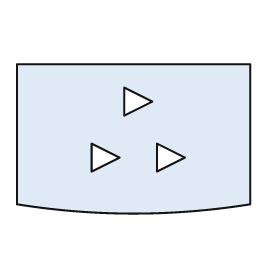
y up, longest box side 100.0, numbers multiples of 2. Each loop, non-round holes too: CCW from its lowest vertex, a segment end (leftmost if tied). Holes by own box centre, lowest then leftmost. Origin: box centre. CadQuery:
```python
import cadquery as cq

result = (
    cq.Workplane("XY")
    .moveTo(-50.0, -28.0)
    .threePointArc((0.0, -32.0), (50.0, -28.0))
    .lineTo(50.0, 32.0)
    .lineTo(-50.0, 32.0)
    .close()
    .moveTo(-18.0, -14.0)
    .lineTo(-6.0, -8.0)
    .lineTo(-18.0, -2.0)
    .close()
    .moveTo(10.0, -14.0)
    .lineTo(22.0, -8.0)
    .lineTo(10.0, -2.0)
    .close()
    .moveTo(-4.0, 10.0)
    .lineTo(8.0, 16.0)
    .lineTo(-4.0, 22.0)
    .close()
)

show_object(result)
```